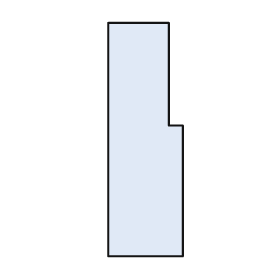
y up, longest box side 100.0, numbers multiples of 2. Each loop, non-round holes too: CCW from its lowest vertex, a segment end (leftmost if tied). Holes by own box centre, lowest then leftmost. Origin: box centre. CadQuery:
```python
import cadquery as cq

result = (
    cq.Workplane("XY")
    .moveTo(-16.0, -50.0)
    .lineTo(16.0, -50.0)
    .lineTo(16.0, 6.0)
    .lineTo(10.0, 6.0)
    .lineTo(10.0, 50.0)
    .lineTo(-16.0, 50.0)
    .close()
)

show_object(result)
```